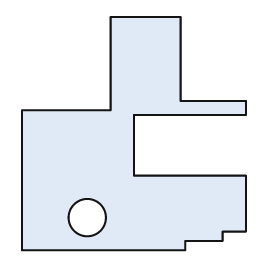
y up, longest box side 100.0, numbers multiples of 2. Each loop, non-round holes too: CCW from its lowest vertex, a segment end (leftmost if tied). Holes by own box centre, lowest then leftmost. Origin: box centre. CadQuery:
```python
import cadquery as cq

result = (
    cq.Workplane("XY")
    .moveTo(-48.0, -50.0)
    .lineTo(22.0, -50.0)
    .lineTo(22.0, -46.0)
    .lineTo(38.0, -46.0)
    .lineTo(38.0, -42.0)
    .lineTo(48.0, -42.0)
    .lineTo(48.0, -18.0)
    .lineTo(0.0, -18.0)
    .lineTo(0.0, 8.0)
    .lineTo(48.0, 8.0)
    .lineTo(48.0, 14.0)
    .lineTo(20.0, 14.0)
    .lineTo(20.0, 50.0)
    .lineTo(-10.0, 50.0)
    .lineTo(-10.0, 10.0)
    .lineTo(-48.0, 10.0)
    .close()
    .moveTo(-20.0, -36.0)
    .circle(8.0)
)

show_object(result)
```